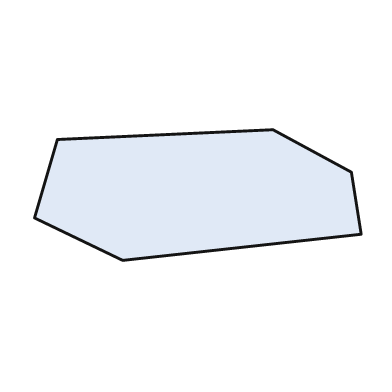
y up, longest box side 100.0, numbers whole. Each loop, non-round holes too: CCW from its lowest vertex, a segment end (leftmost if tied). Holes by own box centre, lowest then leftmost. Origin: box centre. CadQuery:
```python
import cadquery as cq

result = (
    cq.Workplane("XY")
    .moveTo(-23.0, -20.0)
    .lineTo(50.0, -12.0)
    .lineTo(47.0, 7.0)
    .lineTo(23.0, 20.0)
    .lineTo(-43.0, 17.0)
    .lineTo(-50.0, -7.0)
    .close()
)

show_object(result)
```